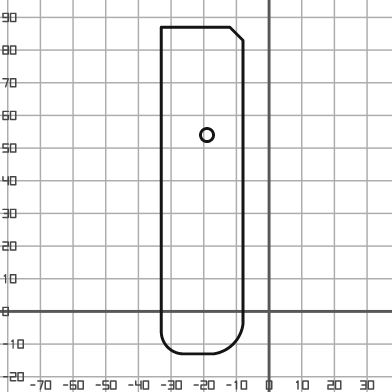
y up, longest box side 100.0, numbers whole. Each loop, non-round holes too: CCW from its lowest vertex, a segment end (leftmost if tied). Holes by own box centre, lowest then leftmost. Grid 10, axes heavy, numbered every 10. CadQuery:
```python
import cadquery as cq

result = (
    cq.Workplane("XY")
    .moveTo(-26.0, -13.0)
    .lineTo(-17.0, -13.0)
    .threePointArc((-11.0, -10.0), (-8.0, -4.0))
    .lineTo(-8.0, 83.0)
    .lineTo(-12.0, 87.0)
    .lineTo(-33.0, 87.0)
    .lineTo(-33.0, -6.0)
    .threePointArc((-31.0, -11.0), (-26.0, -13.0))
    .close()
    .moveTo(-19.0, 54.0)
    .circle(2.0)
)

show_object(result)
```